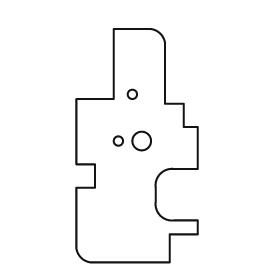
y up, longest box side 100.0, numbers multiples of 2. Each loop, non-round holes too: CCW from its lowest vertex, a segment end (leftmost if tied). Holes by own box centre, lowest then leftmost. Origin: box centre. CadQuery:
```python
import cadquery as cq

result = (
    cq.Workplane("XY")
    .moveTo(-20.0, -50.0)
    .lineTo(14.0, -50.0)
    .lineTo(14.0, -38.0)
    .lineTo(26.0, -38.0)
    .lineTo(26.0, -32.0)
    .lineTo(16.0, -32.0)
    .threePointArc((10.0, -30.0), (8.0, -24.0))
    .lineTo(8.0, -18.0)
    .threePointArc((10.0, -12.0), (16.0, -10.0))
    .lineTo(26.0, -10.0)
    .lineTo(26.0, 8.0)
    .lineTo(20.0, 8.0)
    .lineTo(20.0, 18.0)
    .lineTo(12.0, 18.0)
    .lineTo(12.0, 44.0)
    .threePointArc((10.0, 48.0), (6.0, 50.0))
    .lineTo(-10.0, 50.0)
    .lineTo(-10.0, 20.0)
    .lineTo(-26.0, 20.0)
    .lineTo(-26.0, -8.0)
    .lineTo(-18.0, -8.0)
    .lineTo(-18.0, -18.0)
    .lineTo(-26.0, -18.0)
    .lineTo(-26.0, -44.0)
    .threePointArc((-24.0, -48.0), (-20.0, -50.0))
    .close()
    .moveTo(-8.0, 2.0)
    .circle(2.0)
    .moveTo(2.0, 2.0)
    .circle(4.0)
    .moveTo(-2.0, 22.0)
    .circle(2.0)
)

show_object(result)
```